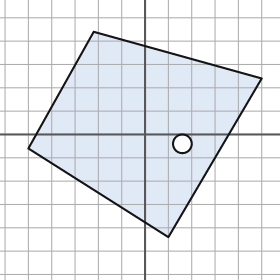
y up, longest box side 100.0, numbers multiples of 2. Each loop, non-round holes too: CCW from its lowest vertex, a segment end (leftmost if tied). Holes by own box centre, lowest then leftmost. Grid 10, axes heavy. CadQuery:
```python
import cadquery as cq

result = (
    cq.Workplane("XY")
    .moveTo(10.0, -44.0)
    .lineTo(50.0, 24.0)
    .lineTo(-22.0, 44.0)
    .lineTo(-50.0, -6.0)
    .close()
    .moveTo(16.0, -4.0)
    .circle(4.0)
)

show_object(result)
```